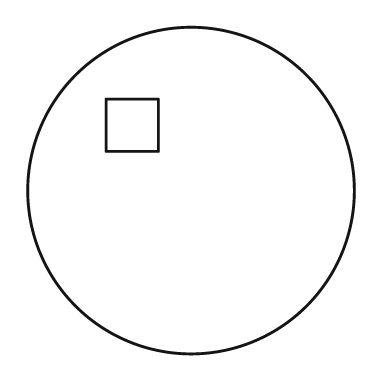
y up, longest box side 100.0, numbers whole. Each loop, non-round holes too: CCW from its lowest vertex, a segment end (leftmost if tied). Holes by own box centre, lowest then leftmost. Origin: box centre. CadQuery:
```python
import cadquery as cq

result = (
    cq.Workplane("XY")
    .moveTo(0.0, 0.0)
    .circle(50.0)
    .moveTo(-26.0, 12.0)
    .lineTo(-10.0, 12.0)
    .lineTo(-10.0, 28.0)
    .lineTo(-26.0, 28.0)
    .close()
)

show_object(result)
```